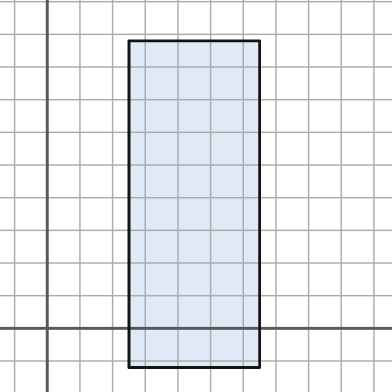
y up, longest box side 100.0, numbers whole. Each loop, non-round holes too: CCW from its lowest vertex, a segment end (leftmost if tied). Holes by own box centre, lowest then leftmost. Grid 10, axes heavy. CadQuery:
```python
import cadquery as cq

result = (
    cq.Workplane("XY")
    .moveTo(25.0, -12.0)
    .lineTo(65.0, -12.0)
    .lineTo(65.0, 88.0)
    .lineTo(25.0, 88.0)
    .close()
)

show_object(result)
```